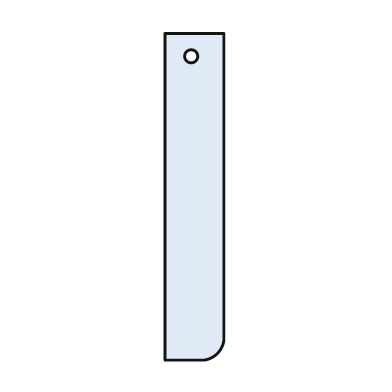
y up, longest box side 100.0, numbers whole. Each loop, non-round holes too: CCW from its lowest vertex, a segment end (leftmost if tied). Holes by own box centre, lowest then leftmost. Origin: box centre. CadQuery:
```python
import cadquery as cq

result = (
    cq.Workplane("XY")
    .moveTo(-9.0, -50.0)
    .lineTo(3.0, -50.0)
    .threePointArc((7.0, -48.0), (9.0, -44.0))
    .lineTo(9.0, 50.0)
    .lineTo(-9.0, 50.0)
    .close()
    .moveTo(-1.0, 43.0)
    .circle(2.0)
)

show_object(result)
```